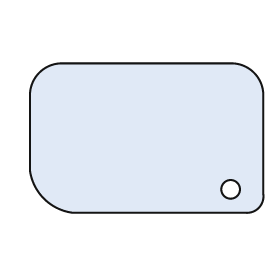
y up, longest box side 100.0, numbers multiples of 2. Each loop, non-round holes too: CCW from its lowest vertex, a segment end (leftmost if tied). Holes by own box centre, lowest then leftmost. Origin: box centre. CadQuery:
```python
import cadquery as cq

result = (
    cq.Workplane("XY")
    .moveTo(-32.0, -32.0)
    .lineTo(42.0, -32.0)
    .threePointArc((48.0, -30.0), (50.0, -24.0))
    .lineTo(50.0, 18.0)
    .threePointArc((46.0, 28.0), (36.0, 32.0))
    .lineTo(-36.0, 32.0)
    .threePointArc((-46.0, 28.0), (-50.0, 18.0))
    .lineTo(-50.0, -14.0)
    .threePointArc((-44.0, -26.0), (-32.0, -32.0))
    .close()
    .moveTo(36.0, -22.0)
    .circle(4.0)
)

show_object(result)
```